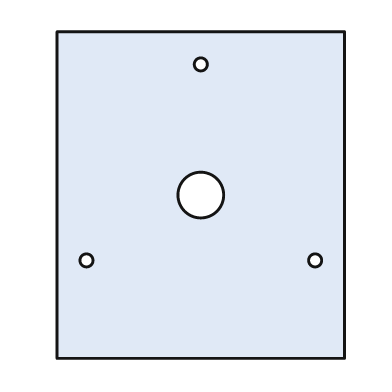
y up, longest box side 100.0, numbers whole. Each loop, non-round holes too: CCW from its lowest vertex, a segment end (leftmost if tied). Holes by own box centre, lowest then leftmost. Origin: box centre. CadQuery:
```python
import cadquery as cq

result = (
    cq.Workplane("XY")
    .moveTo(-44.0, -50.0)
    .lineTo(44.0, -50.0)
    .lineTo(44.0, 50.0)
    .lineTo(-44.0, 50.0)
    .close()
    .moveTo(-35.0, -20.0)
    .circle(2.0)
    .moveTo(35.0, -20.0)
    .circle(2.0)
    .moveTo(0.0, 0.0)
    .circle(7.0)
    .moveTo(0.0, 40.0)
    .circle(2.0)
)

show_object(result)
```